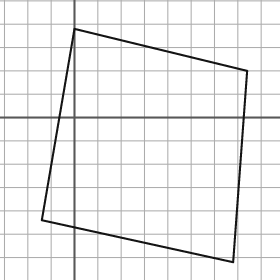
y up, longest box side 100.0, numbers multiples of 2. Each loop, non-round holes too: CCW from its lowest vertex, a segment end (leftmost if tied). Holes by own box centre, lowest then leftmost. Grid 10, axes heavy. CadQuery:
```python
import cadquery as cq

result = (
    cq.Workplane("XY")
    .moveTo(68.0, -62.0)
    .lineTo(74.0, 20.0)
    .lineTo(0.0, 38.0)
    .lineTo(-14.0, -44.0)
    .close()
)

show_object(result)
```